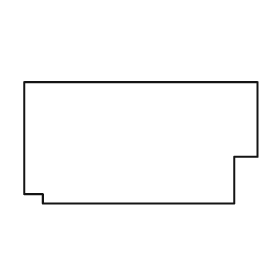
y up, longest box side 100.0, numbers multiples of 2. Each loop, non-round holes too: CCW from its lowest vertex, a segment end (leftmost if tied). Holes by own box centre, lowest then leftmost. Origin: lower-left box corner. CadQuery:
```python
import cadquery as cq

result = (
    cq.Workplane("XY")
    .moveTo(8.0, 0.0)
    .lineTo(90.0, 0.0)
    .lineTo(90.0, 20.0)
    .lineTo(100.0, 20.0)
    .lineTo(100.0, 52.0)
    .lineTo(0.0, 52.0)
    .lineTo(0.0, 4.0)
    .lineTo(8.0, 4.0)
    .close()
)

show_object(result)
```